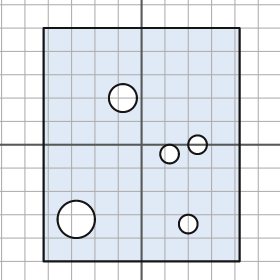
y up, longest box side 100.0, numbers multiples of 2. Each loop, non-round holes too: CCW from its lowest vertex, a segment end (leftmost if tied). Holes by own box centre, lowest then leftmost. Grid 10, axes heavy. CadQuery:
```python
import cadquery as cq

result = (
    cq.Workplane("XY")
    .moveTo(-42.0, -50.0)
    .lineTo(42.0, -50.0)
    .lineTo(42.0, 50.0)
    .lineTo(-42.0, 50.0)
    .close()
    .moveTo(20.0, -34.0)
    .circle(4.0)
    .moveTo(-28.0, -32.0)
    .circle(8.0)
    .moveTo(12.0, -4.0)
    .circle(4.0)
    .moveTo(24.0, 0.0)
    .circle(4.0)
    .moveTo(-8.0, 20.0)
    .circle(6.0)
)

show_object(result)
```